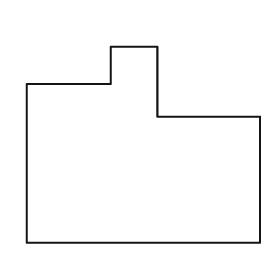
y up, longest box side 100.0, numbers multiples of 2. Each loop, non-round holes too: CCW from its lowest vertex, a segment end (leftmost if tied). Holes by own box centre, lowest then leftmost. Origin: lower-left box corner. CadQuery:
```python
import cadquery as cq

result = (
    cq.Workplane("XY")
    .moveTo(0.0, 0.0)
    .lineTo(100.0, 0.0)
    .lineTo(100.0, 54.0)
    .lineTo(56.0, 54.0)
    .lineTo(56.0, 84.0)
    .lineTo(36.0, 84.0)
    .lineTo(36.0, 68.0)
    .lineTo(0.0, 68.0)
    .close()
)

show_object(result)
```